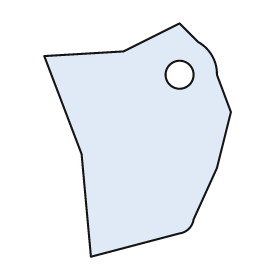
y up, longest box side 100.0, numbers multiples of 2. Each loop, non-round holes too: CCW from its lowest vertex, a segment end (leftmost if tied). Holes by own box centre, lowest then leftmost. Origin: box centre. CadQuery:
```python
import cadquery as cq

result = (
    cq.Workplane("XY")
    .moveTo(-20.0, -50.0)
    .lineTo(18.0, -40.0)
    .threePointArc((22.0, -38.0), (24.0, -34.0))
    .lineTo(34.0, -12.0)
    .lineTo(40.0, 12.0)
    .lineTo(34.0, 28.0)
    .threePointArc((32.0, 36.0), (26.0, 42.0))
    .lineTo(18.0, 50.0)
    .lineTo(-6.0, 38.0)
    .lineTo(-40.0, 36.0)
    .lineTo(-24.0, -6.0)
    .close()
    .moveTo(18.0, 28.0)
    .circle(6.0)
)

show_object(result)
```